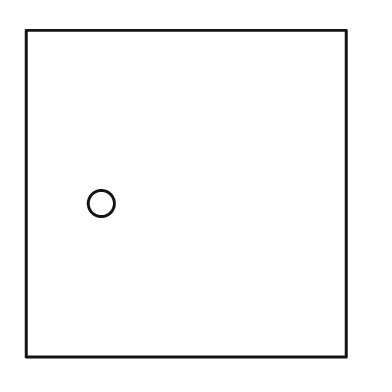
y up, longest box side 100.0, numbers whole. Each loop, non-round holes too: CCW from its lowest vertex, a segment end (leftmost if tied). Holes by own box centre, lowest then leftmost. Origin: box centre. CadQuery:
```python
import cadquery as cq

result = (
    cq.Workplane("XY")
    .moveTo(-49.0, -50.0)
    .lineTo(49.0, -50.0)
    .lineTo(49.0, 50.0)
    .lineTo(-49.0, 50.0)
    .close()
    .moveTo(-26.0, -3.0)
    .circle(4.0)
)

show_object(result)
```